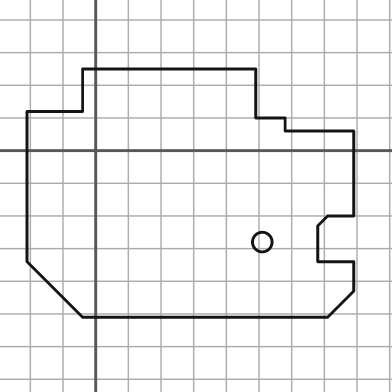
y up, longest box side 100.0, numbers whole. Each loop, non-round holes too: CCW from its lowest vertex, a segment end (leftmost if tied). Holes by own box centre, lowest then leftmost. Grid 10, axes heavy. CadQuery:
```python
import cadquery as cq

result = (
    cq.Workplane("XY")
    .moveTo(-4.0, -51.0)
    .lineTo(71.0, -51.0)
    .lineTo(79.0, -43.0)
    .lineTo(79.0, -34.0)
    .lineTo(68.0, -34.0)
    .lineTo(68.0, -23.0)
    .lineTo(71.0, -20.0)
    .lineTo(79.0, -20.0)
    .lineTo(79.0, 6.0)
    .lineTo(58.0, 6.0)
    .lineTo(58.0, 10.0)
    .lineTo(49.0, 10.0)
    .lineTo(49.0, 25.0)
    .lineTo(-4.0, 25.0)
    .lineTo(-4.0, 12.0)
    .lineTo(-21.0, 12.0)
    .lineTo(-21.0, -34.0)
    .close()
    .moveTo(51.0, -28.0)
    .circle(3.0)
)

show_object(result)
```